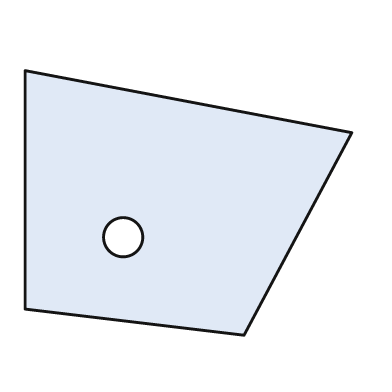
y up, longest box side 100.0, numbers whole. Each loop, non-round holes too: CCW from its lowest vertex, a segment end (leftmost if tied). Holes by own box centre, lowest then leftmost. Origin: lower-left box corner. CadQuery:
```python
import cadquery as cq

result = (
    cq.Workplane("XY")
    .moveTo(67.0, 0.0)
    .lineTo(100.0, 62.0)
    .lineTo(0.0, 81.0)
    .lineTo(0.0, 8.0)
    .close()
    .moveTo(30.0, 30.0)
    .circle(6.0)
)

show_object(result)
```